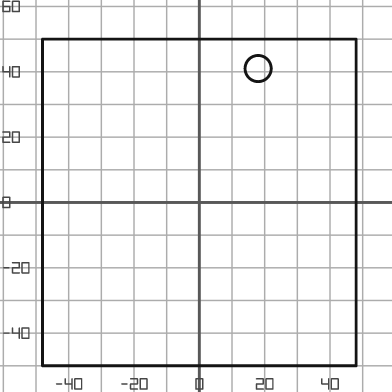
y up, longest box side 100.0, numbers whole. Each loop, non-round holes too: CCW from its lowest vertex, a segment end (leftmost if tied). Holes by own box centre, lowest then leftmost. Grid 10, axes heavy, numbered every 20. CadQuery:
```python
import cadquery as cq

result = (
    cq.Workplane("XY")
    .moveTo(-48.0, -50.0)
    .lineTo(48.0, -50.0)
    .lineTo(48.0, 50.0)
    .lineTo(-48.0, 50.0)
    .close()
    .moveTo(18.0, 41.0)
    .circle(4.0)
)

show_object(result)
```